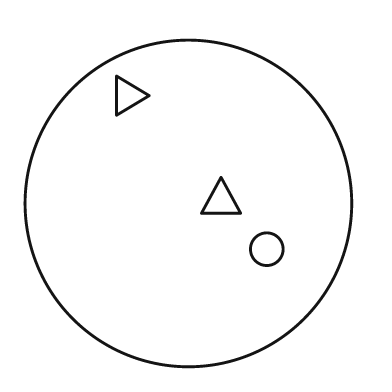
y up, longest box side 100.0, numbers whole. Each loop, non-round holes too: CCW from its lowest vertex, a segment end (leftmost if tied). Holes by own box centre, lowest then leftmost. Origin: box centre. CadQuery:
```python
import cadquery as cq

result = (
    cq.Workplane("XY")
    .moveTo(0.0, 0.0)
    .circle(50.0)
    .moveTo(24.0, -14.0)
    .circle(5.0)
    .moveTo(4.0, -3.0)
    .lineTo(16.0, -3.0)
    .lineTo(10.0, 8.0)
    .close()
    .moveTo(-22.0, 27.0)
    .lineTo(-12.0, 33.0)
    .lineTo(-22.0, 39.0)
    .close()
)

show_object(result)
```